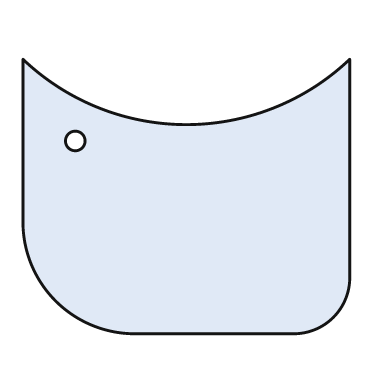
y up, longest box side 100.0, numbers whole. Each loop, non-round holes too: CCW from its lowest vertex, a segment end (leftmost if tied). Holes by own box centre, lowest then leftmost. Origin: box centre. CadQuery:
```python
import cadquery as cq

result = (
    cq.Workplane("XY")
    .moveTo(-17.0, -42.0)
    .lineTo(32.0, -42.0)
    .threePointArc((45.0, -37.0), (50.0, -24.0))
    .lineTo(50.0, 42.0)
    .threePointArc((0.0, 22.0), (-50.0, 42.0))
    .lineTo(-50.0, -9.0)
    .threePointArc((-40.0, -32.0), (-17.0, -42.0))
    .close()
    .moveTo(-34.0, 17.0)
    .circle(3.0)
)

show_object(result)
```